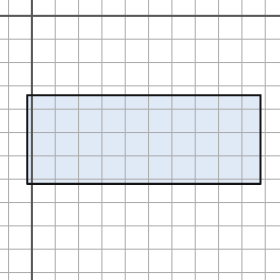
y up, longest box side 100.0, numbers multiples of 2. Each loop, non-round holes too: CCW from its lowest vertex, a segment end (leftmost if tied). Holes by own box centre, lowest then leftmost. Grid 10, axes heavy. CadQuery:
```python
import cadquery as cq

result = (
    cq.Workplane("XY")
    .moveTo(-2.0, -72.0)
    .lineTo(98.0, -72.0)
    .lineTo(98.0, -34.0)
    .lineTo(-2.0, -34.0)
    .close()
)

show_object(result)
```